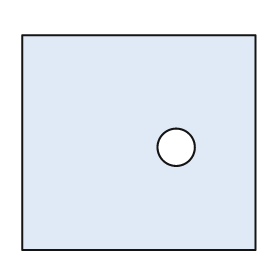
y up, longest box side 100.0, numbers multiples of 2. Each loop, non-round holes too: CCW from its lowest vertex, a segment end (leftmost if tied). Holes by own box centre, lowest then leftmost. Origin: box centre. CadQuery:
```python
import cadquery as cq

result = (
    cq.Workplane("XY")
    .moveTo(-50.0, -46.0)
    .lineTo(50.0, -46.0)
    .lineTo(50.0, 46.0)
    .lineTo(-50.0, 46.0)
    .close()
    .moveTo(16.0, -2.0)
    .circle(8.0)
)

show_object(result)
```